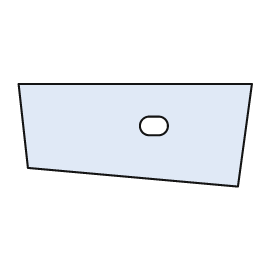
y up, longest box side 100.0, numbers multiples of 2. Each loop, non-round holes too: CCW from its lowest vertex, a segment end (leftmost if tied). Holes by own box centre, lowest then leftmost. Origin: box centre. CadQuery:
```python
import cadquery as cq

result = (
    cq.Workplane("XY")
    .moveTo(44.0, -22.0)
    .lineTo(50.0, 22.0)
    .lineTo(-50.0, 22.0)
    .lineTo(-46.0, -14.0)
    .close()
    .moveTo(6.0, 0.0)
    .lineTo(10.0, 0.0)
    .threePointArc((14.0, 4.0), (10.0, 8.0))
    .lineTo(6.0, 8.0)
    .threePointArc((2.0, 4.0), (6.0, 0.0))
    .close()
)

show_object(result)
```